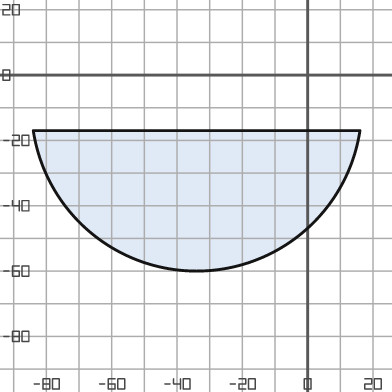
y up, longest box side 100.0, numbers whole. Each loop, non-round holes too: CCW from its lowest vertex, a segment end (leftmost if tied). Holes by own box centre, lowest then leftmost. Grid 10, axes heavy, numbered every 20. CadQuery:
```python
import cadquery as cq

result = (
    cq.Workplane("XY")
    .moveTo(-84.0, -17.0)
    .threePointArc((-34.0, -60.0), (16.0, -17.0))
    .close()
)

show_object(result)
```